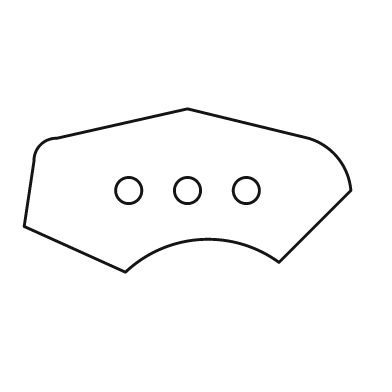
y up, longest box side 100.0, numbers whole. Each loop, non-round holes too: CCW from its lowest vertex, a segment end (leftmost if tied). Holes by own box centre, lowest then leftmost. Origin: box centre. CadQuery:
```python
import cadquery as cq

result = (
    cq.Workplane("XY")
    .moveTo(-19.0, -25.0)
    .threePointArc((4.0, -15.0), (28.0, -22.0))
    .lineTo(50.0, 0.0)
    .threePointArc((46.0, 10.0), (37.0, 16.0))
    .lineTo(0.0, 25.0)
    .lineTo(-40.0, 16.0)
    .threePointArc((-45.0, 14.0), (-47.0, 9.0))
    .lineTo(-50.0, -11.0)
    .close()
    .moveTo(-18.0, 0.0)
    .circle(4.0)
    .moveTo(0.0, 0.0)
    .circle(4.0)
    .moveTo(18.0, 0.0)
    .circle(4.0)
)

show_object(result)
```